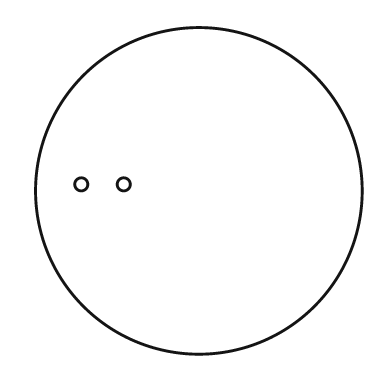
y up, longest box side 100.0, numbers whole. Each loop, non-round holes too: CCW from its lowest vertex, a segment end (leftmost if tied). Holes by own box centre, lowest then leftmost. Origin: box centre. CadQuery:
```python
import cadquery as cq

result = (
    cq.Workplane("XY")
    .moveTo(0.0, 0.0)
    .circle(50.0)
    .moveTo(-36.0, 2.0)
    .circle(2.0)
    .moveTo(-23.0, 2.0)
    .circle(2.0)
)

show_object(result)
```